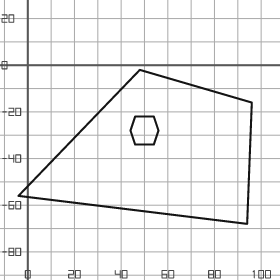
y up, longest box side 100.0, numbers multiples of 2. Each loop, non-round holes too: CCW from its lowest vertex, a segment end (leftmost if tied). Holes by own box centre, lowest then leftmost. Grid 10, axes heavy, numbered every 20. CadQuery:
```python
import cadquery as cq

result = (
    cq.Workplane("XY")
    .moveTo(94.0, -68.0)
    .lineTo(96.0, -16.0)
    .lineTo(48.0, -2.0)
    .lineTo(-4.0, -56.0)
    .close()
    .moveTo(46.0, -34.0)
    .lineTo(54.0, -34.0)
    .lineTo(56.0, -28.0)
    .lineTo(54.0, -22.0)
    .lineTo(46.0, -22.0)
    .lineTo(44.0, -28.0)
    .close()
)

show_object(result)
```